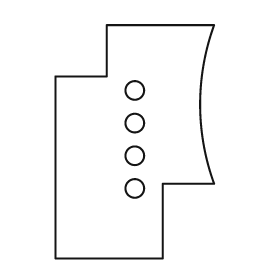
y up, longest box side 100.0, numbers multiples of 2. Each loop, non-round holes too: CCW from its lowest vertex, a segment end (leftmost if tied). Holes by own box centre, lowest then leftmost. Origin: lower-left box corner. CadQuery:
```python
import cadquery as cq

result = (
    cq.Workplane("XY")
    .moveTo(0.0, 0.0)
    .lineTo(46.0, 0.0)
    .lineTo(46.0, 32.0)
    .lineTo(68.0, 32.0)
    .threePointArc((62.0, 66.0), (68.0, 100.0))
    .lineTo(22.0, 100.0)
    .lineTo(22.0, 78.0)
    .lineTo(0.0, 78.0)
    .close()
    .moveTo(34.0, 30.0)
    .circle(4.0)
    .moveTo(34.0, 44.0)
    .circle(4.0)
    .moveTo(34.0, 58.0)
    .circle(4.0)
    .moveTo(34.0, 72.0)
    .circle(4.0)
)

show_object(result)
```